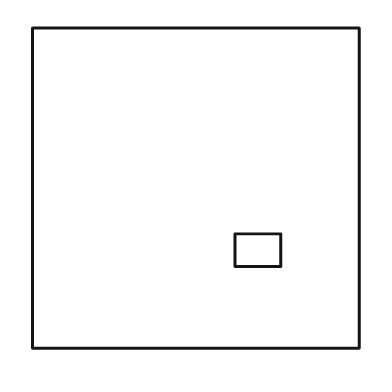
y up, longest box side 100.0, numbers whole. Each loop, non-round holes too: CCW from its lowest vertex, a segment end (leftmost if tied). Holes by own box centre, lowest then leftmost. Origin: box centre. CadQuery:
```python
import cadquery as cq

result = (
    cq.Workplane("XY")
    .moveTo(-50.0, -49.0)
    .lineTo(50.0, -49.0)
    .lineTo(50.0, 49.0)
    .lineTo(-50.0, 49.0)
    .close()
    .moveTo(12.0, -24.0)
    .lineTo(26.0, -24.0)
    .lineTo(26.0, -14.0)
    .lineTo(12.0, -14.0)
    .close()
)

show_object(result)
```